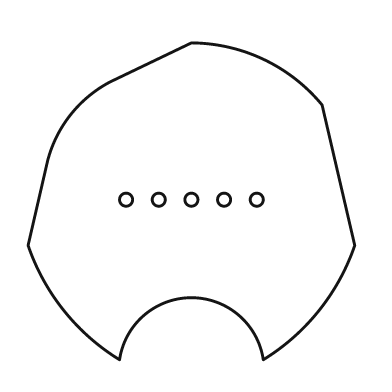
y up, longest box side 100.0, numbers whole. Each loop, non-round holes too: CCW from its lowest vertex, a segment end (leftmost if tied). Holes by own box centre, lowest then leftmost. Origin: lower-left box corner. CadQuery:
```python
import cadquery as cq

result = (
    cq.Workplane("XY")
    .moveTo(28.0, 0.0)
    .threePointArc((50.0, 19.0), (72.0, 0.0))
    .threePointArc((89.0, 15.0), (100.0, 35.0))
    .lineTo(90.0, 78.0)
    .threePointArc((72.0, 92.0), (50.0, 97.0))
    .lineTo(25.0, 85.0)
    .threePointArc((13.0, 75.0), (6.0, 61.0))
    .lineTo(0.0, 35.0)
    .threePointArc((11.0, 15.0), (28.0, 0.0))
    .close()
    .moveTo(30.0, 49.0)
    .circle(2.0)
    .moveTo(40.0, 49.0)
    .circle(2.0)
    .moveTo(50.0, 49.0)
    .circle(2.0)
    .moveTo(60.0, 49.0)
    .circle(2.0)
    .moveTo(70.0, 49.0)
    .circle(2.0)
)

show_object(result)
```